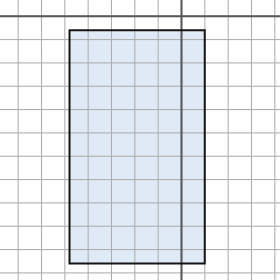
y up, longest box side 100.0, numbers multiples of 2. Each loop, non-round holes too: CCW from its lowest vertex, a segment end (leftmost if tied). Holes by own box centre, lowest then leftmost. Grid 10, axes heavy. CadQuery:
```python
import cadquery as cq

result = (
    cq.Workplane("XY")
    .moveTo(-48.0, -106.0)
    .lineTo(10.0, -106.0)
    .lineTo(10.0, -6.0)
    .lineTo(-48.0, -6.0)
    .close()
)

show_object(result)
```